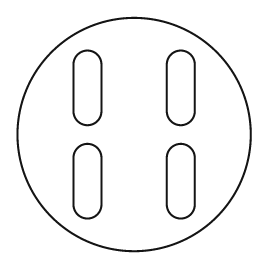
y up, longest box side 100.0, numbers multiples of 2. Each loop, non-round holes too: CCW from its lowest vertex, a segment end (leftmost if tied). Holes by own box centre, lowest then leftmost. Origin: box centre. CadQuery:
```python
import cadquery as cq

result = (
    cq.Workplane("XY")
    .moveTo(0.0, 0.0)
    .circle(50.0)
    .moveTo(-26.0, -30.0)
    .threePointArc((-20.0, -36.0), (-14.0, -30.0))
    .lineTo(-14.0, -10.0)
    .threePointArc((-20.0, -4.0), (-26.0, -10.0))
    .close()
    .moveTo(14.0, -30.0)
    .threePointArc((20.0, -36.0), (26.0, -30.0))
    .lineTo(26.0, -10.0)
    .threePointArc((20.0, -4.0), (14.0, -10.0))
    .close()
    .moveTo(-26.0, 10.0)
    .threePointArc((-20.0, 4.0), (-14.0, 10.0))
    .lineTo(-14.0, 30.0)
    .threePointArc((-20.0, 36.0), (-26.0, 30.0))
    .close()
    .moveTo(14.0, 10.0)
    .threePointArc((20.0, 4.0), (26.0, 10.0))
    .lineTo(26.0, 30.0)
    .threePointArc((20.0, 36.0), (14.0, 30.0))
    .close()
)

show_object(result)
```